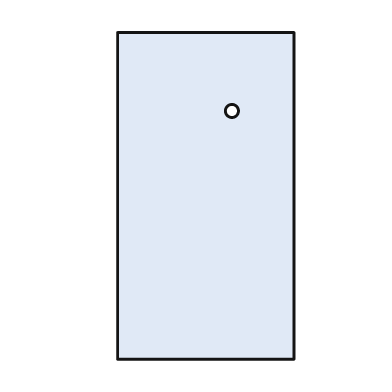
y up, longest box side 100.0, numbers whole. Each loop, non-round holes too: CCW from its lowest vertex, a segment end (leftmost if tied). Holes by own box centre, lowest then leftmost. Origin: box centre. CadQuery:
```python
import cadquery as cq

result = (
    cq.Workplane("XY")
    .moveTo(-27.0, -50.0)
    .lineTo(27.0, -50.0)
    .lineTo(27.0, 50.0)
    .lineTo(-27.0, 50.0)
    .close()
    .moveTo(8.0, 26.0)
    .circle(2.0)
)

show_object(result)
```